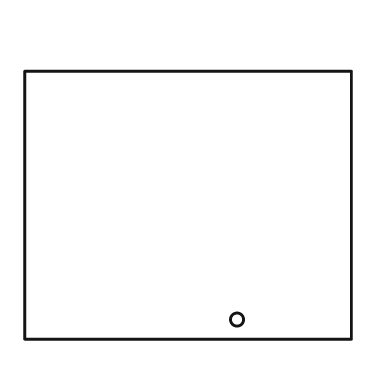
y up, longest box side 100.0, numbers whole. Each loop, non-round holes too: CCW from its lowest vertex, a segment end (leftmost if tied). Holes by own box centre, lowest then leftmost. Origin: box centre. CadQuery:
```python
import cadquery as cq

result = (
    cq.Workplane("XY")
    .moveTo(-50.0, -41.0)
    .lineTo(50.0, -41.0)
    .lineTo(50.0, 41.0)
    .lineTo(-50.0, 41.0)
    .close()
    .moveTo(15.0, -35.0)
    .circle(2.0)
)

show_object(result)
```